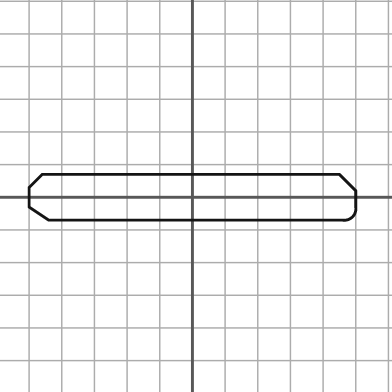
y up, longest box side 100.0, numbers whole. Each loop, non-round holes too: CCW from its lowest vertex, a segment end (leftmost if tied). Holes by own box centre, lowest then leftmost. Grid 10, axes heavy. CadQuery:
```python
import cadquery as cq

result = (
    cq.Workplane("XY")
    .moveTo(-44.0, -7.0)
    .lineTo(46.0, -7.0)
    .threePointArc((49.0, -6.0), (50.0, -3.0))
    .lineTo(50.0, 2.0)
    .lineTo(45.0, 7.0)
    .lineTo(-46.0, 7.0)
    .lineTo(-50.0, 3.0)
    .lineTo(-50.0, -3.0)
    .close()
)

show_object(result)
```